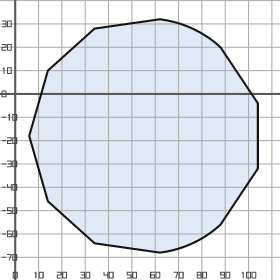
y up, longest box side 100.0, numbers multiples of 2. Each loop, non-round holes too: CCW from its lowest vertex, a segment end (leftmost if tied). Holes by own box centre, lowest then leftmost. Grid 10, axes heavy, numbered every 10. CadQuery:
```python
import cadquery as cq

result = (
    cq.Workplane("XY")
    .moveTo(62.0, -68.0)
    .threePointArc((76.0, -64.0), (88.0, -56.0))
    .lineTo(104.0, -32.0)
    .lineTo(104.0, -4.0)
    .lineTo(88.0, 20.0)
    .threePointArc((76.0, 28.0), (62.0, 32.0))
    .lineTo(34.0, 28.0)
    .lineTo(14.0, 10.0)
    .lineTo(6.0, -18.0)
    .lineTo(14.0, -46.0)
    .lineTo(34.0, -64.0)
    .close()
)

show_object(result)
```